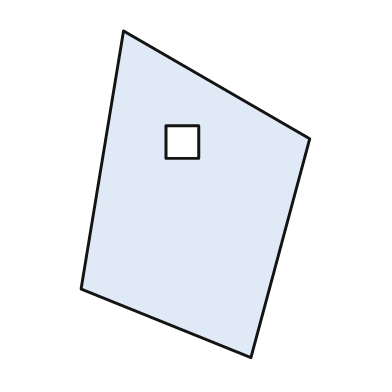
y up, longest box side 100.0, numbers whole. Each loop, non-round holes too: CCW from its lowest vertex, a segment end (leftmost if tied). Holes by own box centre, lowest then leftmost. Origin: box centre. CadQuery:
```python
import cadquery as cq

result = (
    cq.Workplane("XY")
    .moveTo(17.0, -50.0)
    .lineTo(35.0, 17.0)
    .lineTo(-22.0, 50.0)
    .lineTo(-35.0, -29.0)
    .close()
    .moveTo(-9.0, 11.0)
    .lineTo(1.0, 11.0)
    .lineTo(1.0, 21.0)
    .lineTo(-9.0, 21.0)
    .close()
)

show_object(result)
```